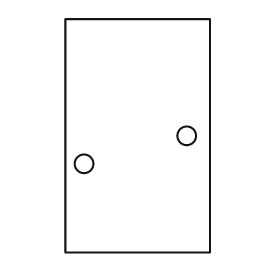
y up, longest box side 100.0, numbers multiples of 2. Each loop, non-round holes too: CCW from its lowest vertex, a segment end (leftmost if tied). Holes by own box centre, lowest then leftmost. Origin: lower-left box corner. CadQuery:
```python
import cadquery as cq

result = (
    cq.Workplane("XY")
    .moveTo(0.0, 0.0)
    .lineTo(62.0, 0.0)
    .lineTo(62.0, 100.0)
    .lineTo(0.0, 100.0)
    .close()
    .moveTo(8.0, 38.0)
    .circle(4.0)
    .moveTo(52.0, 50.0)
    .circle(4.0)
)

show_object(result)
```